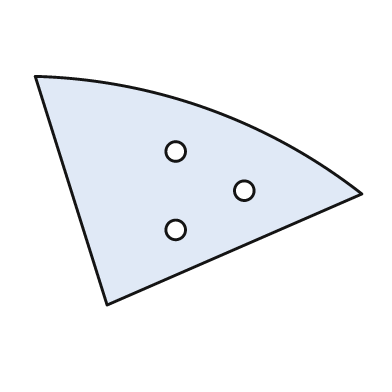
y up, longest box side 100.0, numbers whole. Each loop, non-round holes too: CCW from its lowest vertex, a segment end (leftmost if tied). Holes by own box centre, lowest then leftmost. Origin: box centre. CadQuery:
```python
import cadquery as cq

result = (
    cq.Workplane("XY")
    .moveTo(-28.0, -35.0)
    .lineTo(50.0, -1.0)
    .threePointArc((3.0, 25.0), (-50.0, 35.0))
    .close()
    .moveTo(-7.0, -12.0)
    .circle(3.0)
    .moveTo(14.0, 0.0)
    .circle(3.0)
    .moveTo(-7.0, 12.0)
    .circle(3.0)
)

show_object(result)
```